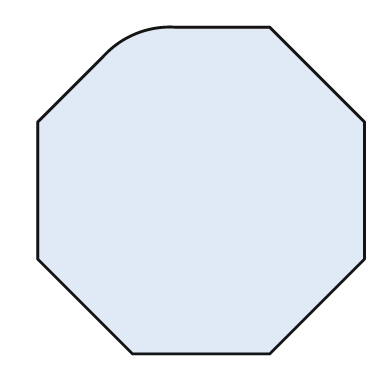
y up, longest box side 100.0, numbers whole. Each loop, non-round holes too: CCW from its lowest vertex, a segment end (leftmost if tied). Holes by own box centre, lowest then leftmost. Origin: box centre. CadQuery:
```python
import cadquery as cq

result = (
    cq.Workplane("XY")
    .moveTo(-21.0, -50.0)
    .lineTo(21.0, -50.0)
    .lineTo(50.0, -21.0)
    .lineTo(50.0, 21.0)
    .lineTo(21.0, 50.0)
    .lineTo(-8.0, 50.0)
    .threePointArc((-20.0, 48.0), (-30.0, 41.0))
    .lineTo(-50.0, 21.0)
    .lineTo(-50.0, -21.0)
    .close()
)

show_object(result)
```